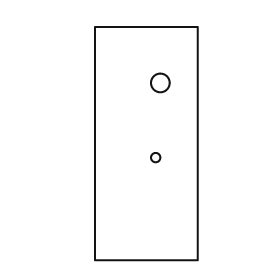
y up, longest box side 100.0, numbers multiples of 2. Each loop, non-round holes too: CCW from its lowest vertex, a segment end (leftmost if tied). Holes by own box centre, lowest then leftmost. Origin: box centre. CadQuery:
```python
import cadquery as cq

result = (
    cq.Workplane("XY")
    .moveTo(-22.0, -50.0)
    .lineTo(22.0, -50.0)
    .lineTo(22.0, 50.0)
    .lineTo(-22.0, 50.0)
    .close()
    .moveTo(4.0, -6.0)
    .circle(2.0)
    .moveTo(6.0, 26.0)
    .circle(4.0)
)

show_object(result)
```